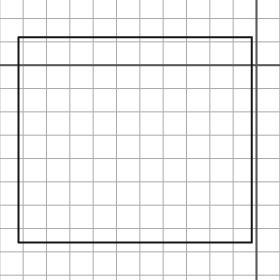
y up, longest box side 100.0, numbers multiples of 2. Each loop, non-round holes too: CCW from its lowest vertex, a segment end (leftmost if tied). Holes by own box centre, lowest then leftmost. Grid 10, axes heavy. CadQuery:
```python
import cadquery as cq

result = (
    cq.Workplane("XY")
    .moveTo(-102.0, -76.0)
    .lineTo(-2.0, -76.0)
    .lineTo(-2.0, 12.0)
    .lineTo(-102.0, 12.0)
    .close()
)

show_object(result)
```